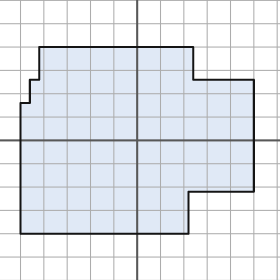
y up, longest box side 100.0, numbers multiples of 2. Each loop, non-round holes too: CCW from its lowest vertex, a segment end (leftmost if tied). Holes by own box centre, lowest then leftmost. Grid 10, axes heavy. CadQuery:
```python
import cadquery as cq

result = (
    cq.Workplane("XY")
    .moveTo(-50.0, -40.0)
    .lineTo(22.0, -40.0)
    .lineTo(22.0, -22.0)
    .lineTo(50.0, -22.0)
    .lineTo(50.0, 26.0)
    .lineTo(24.0, 26.0)
    .lineTo(24.0, 40.0)
    .lineTo(-42.0, 40.0)
    .lineTo(-42.0, 26.0)
    .lineTo(-46.0, 26.0)
    .lineTo(-46.0, 16.0)
    .lineTo(-50.0, 16.0)
    .close()
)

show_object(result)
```